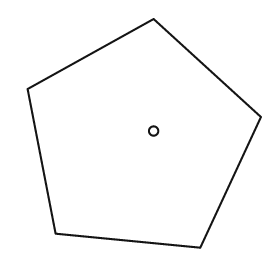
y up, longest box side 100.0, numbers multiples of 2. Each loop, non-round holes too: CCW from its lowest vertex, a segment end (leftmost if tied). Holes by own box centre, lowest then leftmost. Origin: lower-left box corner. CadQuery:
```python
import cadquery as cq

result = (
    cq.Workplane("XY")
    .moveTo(74.0, 0.0)
    .lineTo(100.0, 56.0)
    .lineTo(54.0, 98.0)
    .lineTo(0.0, 68.0)
    .lineTo(12.0, 6.0)
    .close()
    .moveTo(54.0, 50.0)
    .circle(2.0)
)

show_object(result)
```